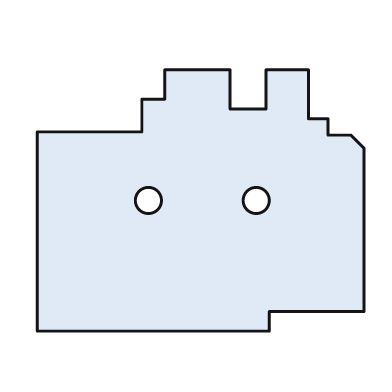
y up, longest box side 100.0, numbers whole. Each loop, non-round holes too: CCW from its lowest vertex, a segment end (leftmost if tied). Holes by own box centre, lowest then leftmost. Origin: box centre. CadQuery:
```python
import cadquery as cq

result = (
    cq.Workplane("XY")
    .moveTo(-50.0, -40.0)
    .lineTo(21.0, -40.0)
    .lineTo(21.0, -34.0)
    .lineTo(50.0, -34.0)
    .lineTo(50.0, 16.0)
    .lineTo(46.0, 20.0)
    .lineTo(39.0, 20.0)
    .lineTo(39.0, 25.0)
    .lineTo(33.0, 25.0)
    .lineTo(33.0, 40.0)
    .lineTo(20.0, 40.0)
    .lineTo(20.0, 28.0)
    .lineTo(9.0, 28.0)
    .lineTo(9.0, 40.0)
    .lineTo(-11.0, 40.0)
    .lineTo(-11.0, 31.0)
    .lineTo(-18.0, 31.0)
    .lineTo(-18.0, 21.0)
    .lineTo(-50.0, 21.0)
    .close()
    .moveTo(-16.0, 0.0)
    .circle(4.0)
    .moveTo(17.0, 0.0)
    .circle(4.0)
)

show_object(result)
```